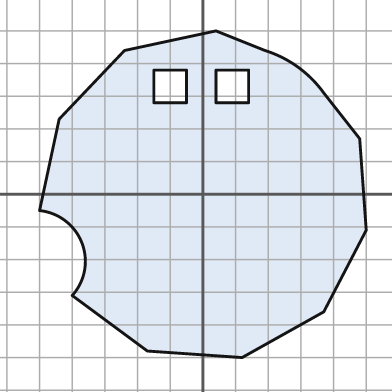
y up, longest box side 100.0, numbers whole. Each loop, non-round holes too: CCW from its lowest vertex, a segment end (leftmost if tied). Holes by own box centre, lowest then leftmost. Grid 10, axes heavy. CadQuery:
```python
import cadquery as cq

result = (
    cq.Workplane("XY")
    .moveTo(12.0, -50.0)
    .lineTo(37.0, -36.0)
    .lineTo(50.0, -11.0)
    .lineTo(48.0, 17.0)
    .lineTo(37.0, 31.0)
    .threePointArc((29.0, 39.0), (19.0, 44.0))
    .lineTo(4.0, 50.0)
    .lineTo(-24.0, 44.0)
    .lineTo(-44.0, 23.0)
    .lineTo(-50.0, -5.0)
    .threePointArc((-37.0, -15.0), (-40.0, -31.0))
    .lineTo(-17.0, -48.0)
    .close()
    .moveTo(-15.0, 28.0)
    .lineTo(-5.0, 28.0)
    .lineTo(-5.0, 38.0)
    .lineTo(-15.0, 38.0)
    .close()
    .moveTo(4.0, 28.0)
    .lineTo(14.0, 28.0)
    .lineTo(14.0, 38.0)
    .lineTo(4.0, 38.0)
    .close()
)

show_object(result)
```